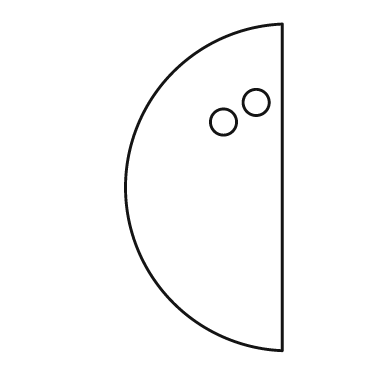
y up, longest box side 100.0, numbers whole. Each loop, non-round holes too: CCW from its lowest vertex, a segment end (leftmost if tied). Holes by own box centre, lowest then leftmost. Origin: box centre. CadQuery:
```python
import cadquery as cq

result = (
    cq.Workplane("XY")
    .moveTo(24.0, -50.0)
    .lineTo(24.0, 50.0)
    .threePointArc((-24.0, 0.0), (24.0, -50.0))
    .close()
    .moveTo(6.0, 20.0)
    .circle(4.0)
    .moveTo(16.0, 26.0)
    .circle(4.0)
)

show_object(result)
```